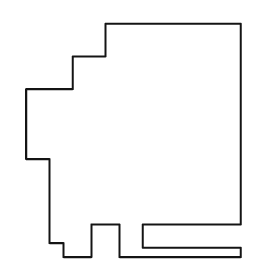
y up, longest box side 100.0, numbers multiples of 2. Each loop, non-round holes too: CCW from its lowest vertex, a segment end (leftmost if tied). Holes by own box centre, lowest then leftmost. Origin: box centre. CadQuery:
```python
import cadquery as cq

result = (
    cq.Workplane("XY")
    .moveTo(-30.0, -50.0)
    .lineTo(-18.0, -50.0)
    .lineTo(-18.0, -36.0)
    .lineTo(-6.0, -36.0)
    .lineTo(-6.0, -50.0)
    .lineTo(46.0, -50.0)
    .lineTo(46.0, -46.0)
    .lineTo(4.0, -46.0)
    .lineTo(4.0, -36.0)
    .lineTo(46.0, -36.0)
    .lineTo(46.0, 50.0)
    .lineTo(-12.0, 50.0)
    .lineTo(-12.0, 36.0)
    .lineTo(-26.0, 36.0)
    .lineTo(-26.0, 22.0)
    .lineTo(-46.0, 22.0)
    .lineTo(-46.0, -8.0)
    .lineTo(-36.0, -8.0)
    .lineTo(-36.0, -44.0)
    .lineTo(-30.0, -44.0)
    .close()
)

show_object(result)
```